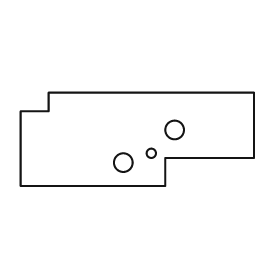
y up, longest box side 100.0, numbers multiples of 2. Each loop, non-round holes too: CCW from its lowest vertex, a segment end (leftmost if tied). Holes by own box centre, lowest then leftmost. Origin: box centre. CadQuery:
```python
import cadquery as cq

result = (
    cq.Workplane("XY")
    .moveTo(-50.0, -20.0)
    .lineTo(12.0, -20.0)
    .lineTo(12.0, -8.0)
    .lineTo(50.0, -8.0)
    .lineTo(50.0, 20.0)
    .lineTo(-38.0, 20.0)
    .lineTo(-38.0, 12.0)
    .lineTo(-50.0, 12.0)
    .close()
    .moveTo(-6.0, -10.0)
    .circle(4.0)
    .moveTo(6.0, -6.0)
    .circle(2.0)
    .moveTo(16.0, 4.0)
    .circle(4.0)
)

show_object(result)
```